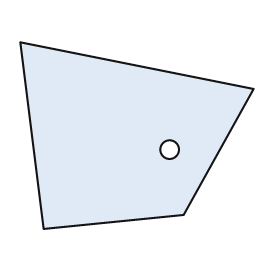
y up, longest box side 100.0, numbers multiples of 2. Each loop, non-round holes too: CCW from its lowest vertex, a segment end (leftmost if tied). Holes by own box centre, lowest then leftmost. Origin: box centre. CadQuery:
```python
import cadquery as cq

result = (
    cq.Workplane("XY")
    .moveTo(-40.0, -40.0)
    .lineTo(20.0, -34.0)
    .lineTo(50.0, 20.0)
    .lineTo(-50.0, 40.0)
    .close()
    .moveTo(14.0, -6.0)
    .circle(4.0)
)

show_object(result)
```